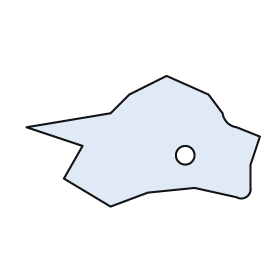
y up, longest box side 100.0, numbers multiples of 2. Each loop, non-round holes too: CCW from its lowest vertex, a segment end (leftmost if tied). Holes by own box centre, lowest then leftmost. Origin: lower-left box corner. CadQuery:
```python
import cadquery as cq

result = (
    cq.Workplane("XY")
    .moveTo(36.0, 0.0)
    .lineTo(52.0, 6.0)
    .lineTo(72.0, 8.0)
    .lineTo(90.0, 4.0)
    .threePointArc((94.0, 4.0), (96.0, 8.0))
    .lineTo(96.0, 18.0)
    .lineTo(100.0, 30.0)
    .lineTo(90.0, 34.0)
    .threePointArc((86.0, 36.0), (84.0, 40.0))
    .lineTo(78.0, 48.0)
    .lineTo(60.0, 56.0)
    .lineTo(44.0, 48.0)
    .lineTo(36.0, 40.0)
    .lineTo(0.0, 34.0)
    .lineTo(24.0, 26.0)
    .lineTo(16.0, 12.0)
    .close()
    .moveTo(68.0, 22.0)
    .circle(4.0)
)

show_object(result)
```